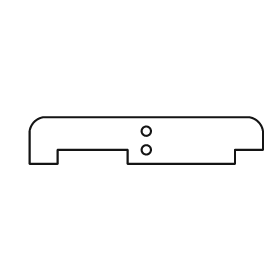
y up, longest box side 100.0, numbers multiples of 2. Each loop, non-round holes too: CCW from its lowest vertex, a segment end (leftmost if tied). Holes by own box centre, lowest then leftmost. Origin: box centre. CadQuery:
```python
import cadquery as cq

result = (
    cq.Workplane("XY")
    .moveTo(-50.0, -10.0)
    .lineTo(-38.0, -10.0)
    .lineTo(-38.0, -4.0)
    .lineTo(-8.0, -4.0)
    .lineTo(-8.0, -10.0)
    .lineTo(38.0, -10.0)
    .lineTo(38.0, -4.0)
    .lineTo(50.0, -4.0)
    .lineTo(50.0, 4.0)
    .threePointArc((48.0, 8.0), (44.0, 10.0))
    .lineTo(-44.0, 10.0)
    .threePointArc((-48.0, 8.0), (-50.0, 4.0))
    .close()
    .moveTo(0.0, -4.0)
    .circle(2.0)
    .moveTo(0.0, 4.0)
    .circle(2.0)
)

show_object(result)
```